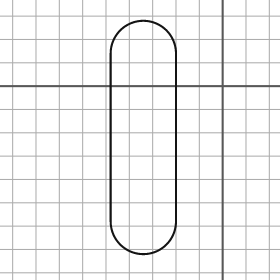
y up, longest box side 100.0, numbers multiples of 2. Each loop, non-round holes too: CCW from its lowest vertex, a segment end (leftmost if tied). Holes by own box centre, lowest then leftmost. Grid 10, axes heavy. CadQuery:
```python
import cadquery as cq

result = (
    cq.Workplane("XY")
    .moveTo(-48.0, -58.0)
    .threePointArc((-34.0, -72.0), (-20.0, -58.0))
    .lineTo(-20.0, 14.0)
    .threePointArc((-34.0, 28.0), (-48.0, 14.0))
    .close()
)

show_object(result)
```